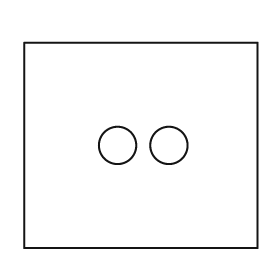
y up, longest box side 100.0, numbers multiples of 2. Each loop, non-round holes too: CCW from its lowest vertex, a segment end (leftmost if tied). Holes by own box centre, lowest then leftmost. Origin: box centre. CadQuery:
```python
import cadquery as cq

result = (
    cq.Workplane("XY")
    .moveTo(-50.0, -44.0)
    .lineTo(50.0, -44.0)
    .lineTo(50.0, 44.0)
    .lineTo(-50.0, 44.0)
    .close()
    .moveTo(-10.0, 0.0)
    .circle(8.0)
    .moveTo(12.0, 0.0)
    .circle(8.0)
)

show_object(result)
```